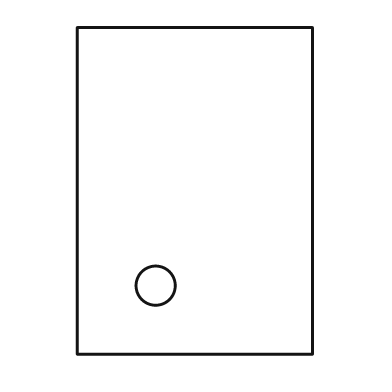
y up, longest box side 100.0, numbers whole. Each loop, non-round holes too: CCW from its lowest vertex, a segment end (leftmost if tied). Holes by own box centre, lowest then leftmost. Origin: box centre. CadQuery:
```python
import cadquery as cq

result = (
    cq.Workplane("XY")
    .moveTo(-36.0, -50.0)
    .lineTo(36.0, -50.0)
    .lineTo(36.0, 50.0)
    .lineTo(-36.0, 50.0)
    .close()
    .moveTo(-12.0, -29.0)
    .circle(6.0)
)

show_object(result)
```